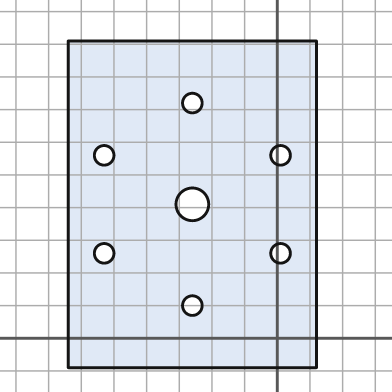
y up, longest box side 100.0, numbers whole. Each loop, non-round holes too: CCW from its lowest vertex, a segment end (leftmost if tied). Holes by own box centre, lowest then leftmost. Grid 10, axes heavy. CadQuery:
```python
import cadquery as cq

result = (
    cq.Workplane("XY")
    .moveTo(-64.0, -9.0)
    .lineTo(12.0, -9.0)
    .lineTo(12.0, 91.0)
    .lineTo(-64.0, 91.0)
    .close()
    .moveTo(-26.0, 10.0)
    .circle(3.0)
    .moveTo(-53.0, 26.0)
    .circle(3.0)
    .moveTo(1.0, 26.0)
    .circle(3.0)
    .moveTo(-26.0, 41.0)
    .circle(5.0)
    .moveTo(-53.0, 56.0)
    .circle(3.0)
    .moveTo(1.0, 56.0)
    .circle(3.0)
    .moveTo(-26.0, 72.0)
    .circle(3.0)
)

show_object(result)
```